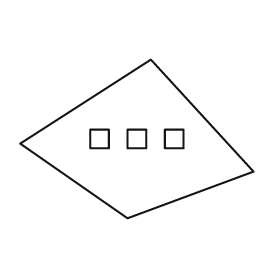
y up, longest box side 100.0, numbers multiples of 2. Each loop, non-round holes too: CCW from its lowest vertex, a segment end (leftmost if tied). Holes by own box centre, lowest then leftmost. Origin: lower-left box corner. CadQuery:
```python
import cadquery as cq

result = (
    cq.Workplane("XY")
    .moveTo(46.0, 0.0)
    .lineTo(100.0, 20.0)
    .lineTo(56.0, 68.0)
    .lineTo(0.0, 32.0)
    .close()
    .moveTo(30.0, 30.0)
    .lineTo(38.0, 30.0)
    .lineTo(38.0, 38.0)
    .lineTo(30.0, 38.0)
    .close()
    .moveTo(46.0, 30.0)
    .lineTo(54.0, 30.0)
    .lineTo(54.0, 38.0)
    .lineTo(46.0, 38.0)
    .close()
    .moveTo(62.0, 30.0)
    .lineTo(70.0, 30.0)
    .lineTo(70.0, 38.0)
    .lineTo(62.0, 38.0)
    .close()
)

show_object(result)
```